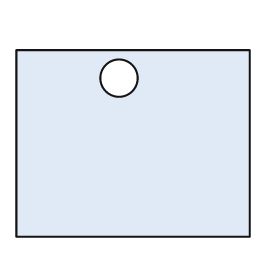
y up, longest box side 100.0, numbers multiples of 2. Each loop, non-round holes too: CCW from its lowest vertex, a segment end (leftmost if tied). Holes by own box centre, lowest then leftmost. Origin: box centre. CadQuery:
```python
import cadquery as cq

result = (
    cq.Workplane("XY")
    .moveTo(-50.0, -40.0)
    .lineTo(50.0, -40.0)
    .lineTo(50.0, 40.0)
    .lineTo(-50.0, 40.0)
    .close()
    .moveTo(-6.0, 28.0)
    .circle(8.0)
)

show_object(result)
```